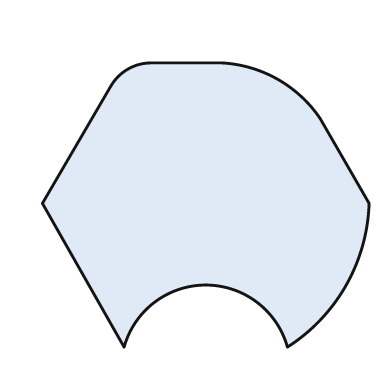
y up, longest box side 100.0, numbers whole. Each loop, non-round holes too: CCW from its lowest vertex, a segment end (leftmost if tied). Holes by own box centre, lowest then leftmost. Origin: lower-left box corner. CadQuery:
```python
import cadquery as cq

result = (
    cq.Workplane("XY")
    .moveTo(25.0, 0.0)
    .threePointArc((50.0, 19.0), (75.0, 0.0))
    .threePointArc((93.0, 19.0), (100.0, 44.0))
    .lineTo(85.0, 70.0)
    .threePointArc((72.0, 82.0), (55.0, 87.0))
    .lineTo(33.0, 87.0)
    .threePointArc((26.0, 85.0), (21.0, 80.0))
    .lineTo(0.0, 44.0)
    .close()
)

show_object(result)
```